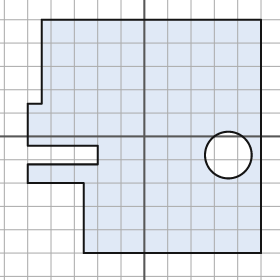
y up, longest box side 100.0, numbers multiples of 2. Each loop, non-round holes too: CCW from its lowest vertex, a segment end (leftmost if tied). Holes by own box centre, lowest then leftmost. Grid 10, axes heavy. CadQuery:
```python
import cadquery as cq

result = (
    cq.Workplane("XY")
    .moveTo(-26.0, -50.0)
    .lineTo(50.0, -50.0)
    .lineTo(50.0, 50.0)
    .lineTo(-44.0, 50.0)
    .lineTo(-44.0, 14.0)
    .lineTo(-50.0, 14.0)
    .lineTo(-50.0, -4.0)
    .lineTo(-20.0, -4.0)
    .lineTo(-20.0, -12.0)
    .lineTo(-50.0, -12.0)
    .lineTo(-50.0, -20.0)
    .lineTo(-26.0, -20.0)
    .close()
    .moveTo(36.0, -8.0)
    .circle(10.0)
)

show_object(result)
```